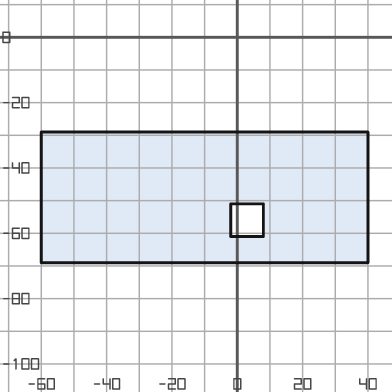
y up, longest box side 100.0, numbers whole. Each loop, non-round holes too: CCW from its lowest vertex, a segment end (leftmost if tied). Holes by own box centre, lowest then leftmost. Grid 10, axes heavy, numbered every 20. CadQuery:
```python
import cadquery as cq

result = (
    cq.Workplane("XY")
    .moveTo(-60.0, -69.0)
    .lineTo(40.0, -69.0)
    .lineTo(40.0, -29.0)
    .lineTo(-60.0, -29.0)
    .close()
    .moveTo(-2.0, -61.0)
    .lineTo(8.0, -61.0)
    .lineTo(8.0, -51.0)
    .lineTo(-2.0, -51.0)
    .close()
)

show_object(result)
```